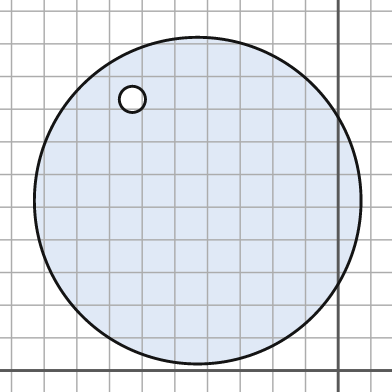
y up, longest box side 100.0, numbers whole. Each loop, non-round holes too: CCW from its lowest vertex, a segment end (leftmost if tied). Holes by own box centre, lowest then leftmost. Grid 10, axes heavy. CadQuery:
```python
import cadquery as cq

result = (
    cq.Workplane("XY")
    .moveTo(-43.0, 52.0)
    .circle(50.0)
    .moveTo(-63.0, 83.0)
    .circle(4.0)
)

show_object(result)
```